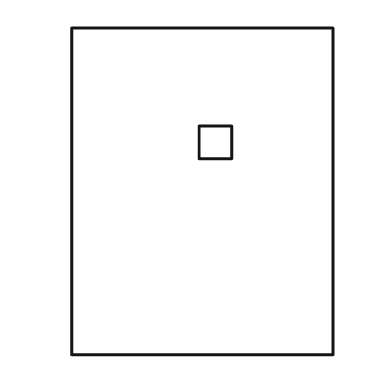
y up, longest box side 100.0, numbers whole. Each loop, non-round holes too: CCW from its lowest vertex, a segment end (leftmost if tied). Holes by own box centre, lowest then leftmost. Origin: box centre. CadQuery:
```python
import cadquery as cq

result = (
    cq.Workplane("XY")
    .moveTo(-40.0, -50.0)
    .lineTo(40.0, -50.0)
    .lineTo(40.0, 50.0)
    .lineTo(-40.0, 50.0)
    .close()
    .moveTo(-1.0, 10.0)
    .lineTo(9.0, 10.0)
    .lineTo(9.0, 20.0)
    .lineTo(-1.0, 20.0)
    .close()
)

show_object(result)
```